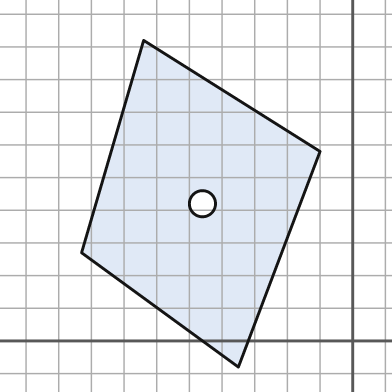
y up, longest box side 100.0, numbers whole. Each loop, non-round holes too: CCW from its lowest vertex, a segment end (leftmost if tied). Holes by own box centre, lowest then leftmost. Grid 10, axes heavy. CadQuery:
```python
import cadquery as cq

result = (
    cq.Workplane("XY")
    .moveTo(-35.0, -8.0)
    .lineTo(-10.0, 58.0)
    .lineTo(-64.0, 92.0)
    .lineTo(-83.0, 27.0)
    .close()
    .moveTo(-46.0, 42.0)
    .circle(4.0)
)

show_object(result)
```